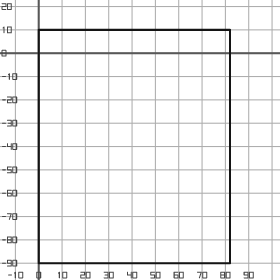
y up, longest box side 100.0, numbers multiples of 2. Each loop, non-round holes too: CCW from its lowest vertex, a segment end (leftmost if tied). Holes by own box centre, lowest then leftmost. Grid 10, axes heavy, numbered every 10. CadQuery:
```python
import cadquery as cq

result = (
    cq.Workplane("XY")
    .moveTo(0.0, -90.0)
    .lineTo(82.0, -90.0)
    .lineTo(82.0, 10.0)
    .lineTo(0.0, 10.0)
    .close()
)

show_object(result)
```